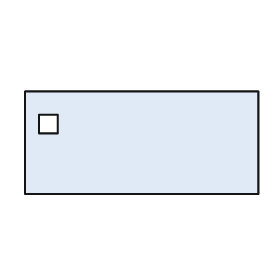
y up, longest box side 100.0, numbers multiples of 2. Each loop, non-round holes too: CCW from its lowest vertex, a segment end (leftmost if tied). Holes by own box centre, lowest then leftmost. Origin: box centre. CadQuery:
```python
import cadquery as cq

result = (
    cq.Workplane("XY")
    .moveTo(-50.0, -22.0)
    .lineTo(50.0, -22.0)
    .lineTo(50.0, 22.0)
    .lineTo(-50.0, 22.0)
    .close()
    .moveTo(-44.0, 4.0)
    .lineTo(-36.0, 4.0)
    .lineTo(-36.0, 12.0)
    .lineTo(-44.0, 12.0)
    .close()
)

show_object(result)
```